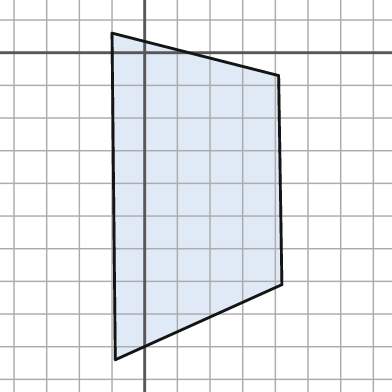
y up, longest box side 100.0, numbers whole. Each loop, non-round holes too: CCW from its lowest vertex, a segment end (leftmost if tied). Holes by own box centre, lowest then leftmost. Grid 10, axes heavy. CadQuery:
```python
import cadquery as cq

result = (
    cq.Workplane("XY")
    .moveTo(-9.0, -94.0)
    .lineTo(42.0, -71.0)
    .lineTo(41.0, -7.0)
    .lineTo(-10.0, 6.0)
    .close()
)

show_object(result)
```